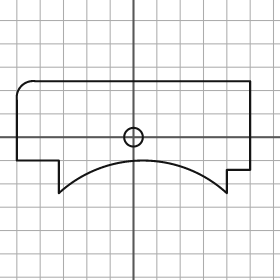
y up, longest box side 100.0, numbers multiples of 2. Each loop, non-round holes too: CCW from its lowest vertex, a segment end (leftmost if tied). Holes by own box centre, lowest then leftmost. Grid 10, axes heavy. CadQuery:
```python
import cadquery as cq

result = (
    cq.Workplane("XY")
    .moveTo(-32.0, -24.0)
    .threePointArc((4.0, -10.0), (40.0, -24.0))
    .lineTo(40.0, -14.0)
    .lineTo(50.0, -14.0)
    .lineTo(50.0, 24.0)
    .lineTo(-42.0, 24.0)
    .threePointArc((-48.0, 22.0), (-50.0, 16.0))
    .lineTo(-50.0, -10.0)
    .lineTo(-32.0, -10.0)
    .close()
    .moveTo(0.0, 0.0)
    .circle(4.0)
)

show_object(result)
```